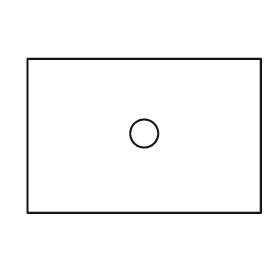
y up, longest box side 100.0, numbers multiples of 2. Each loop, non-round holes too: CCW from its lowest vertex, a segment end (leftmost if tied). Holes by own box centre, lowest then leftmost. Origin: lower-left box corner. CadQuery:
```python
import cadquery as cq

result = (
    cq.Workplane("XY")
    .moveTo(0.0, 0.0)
    .lineTo(100.0, 0.0)
    .lineTo(100.0, 66.0)
    .lineTo(0.0, 66.0)
    .close()
    .moveTo(50.0, 34.0)
    .circle(6.0)
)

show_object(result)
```